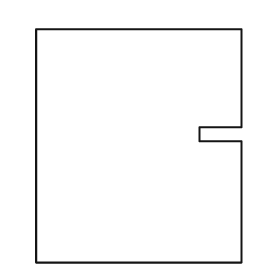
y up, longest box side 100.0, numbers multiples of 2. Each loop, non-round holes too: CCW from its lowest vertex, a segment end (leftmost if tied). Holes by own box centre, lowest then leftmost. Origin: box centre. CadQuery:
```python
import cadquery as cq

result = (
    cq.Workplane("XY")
    .moveTo(-44.0, -50.0)
    .lineTo(44.0, -50.0)
    .lineTo(44.0, 2.0)
    .lineTo(26.0, 2.0)
    .lineTo(26.0, 8.0)
    .lineTo(44.0, 8.0)
    .lineTo(44.0, 50.0)
    .lineTo(-44.0, 50.0)
    .close()
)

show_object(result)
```